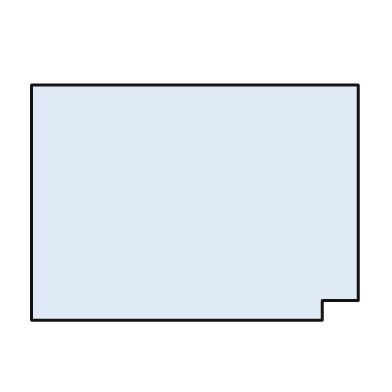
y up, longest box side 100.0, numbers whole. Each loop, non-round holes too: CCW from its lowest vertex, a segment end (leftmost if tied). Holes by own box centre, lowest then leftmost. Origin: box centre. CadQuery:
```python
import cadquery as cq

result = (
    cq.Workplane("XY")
    .moveTo(-50.0, -36.0)
    .lineTo(39.0, -36.0)
    .lineTo(39.0, -30.0)
    .lineTo(50.0, -30.0)
    .lineTo(50.0, 36.0)
    .lineTo(-50.0, 36.0)
    .close()
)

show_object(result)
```